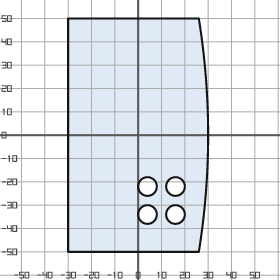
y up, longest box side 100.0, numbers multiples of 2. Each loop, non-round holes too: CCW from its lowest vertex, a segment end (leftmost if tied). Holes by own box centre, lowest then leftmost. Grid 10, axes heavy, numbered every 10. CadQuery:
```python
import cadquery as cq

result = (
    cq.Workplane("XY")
    .moveTo(-30.0, -50.0)
    .lineTo(26.0, -50.0)
    .threePointArc((30.0, 0.0), (26.0, 50.0))
    .lineTo(-30.0, 50.0)
    .close()
    .moveTo(4.0, -34.0)
    .circle(4.0)
    .moveTo(16.0, -34.0)
    .circle(4.0)
    .moveTo(4.0, -22.0)
    .circle(4.0)
    .moveTo(16.0, -22.0)
    .circle(4.0)
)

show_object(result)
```